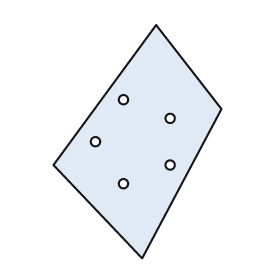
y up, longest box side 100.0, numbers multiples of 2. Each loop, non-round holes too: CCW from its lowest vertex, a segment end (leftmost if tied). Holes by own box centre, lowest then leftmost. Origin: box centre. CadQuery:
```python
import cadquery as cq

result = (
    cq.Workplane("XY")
    .moveTo(2.0, -50.0)
    .lineTo(36.0, 14.0)
    .lineTo(8.0, 50.0)
    .lineTo(-36.0, -10.0)
    .close()
    .moveTo(-6.0, -18.0)
    .circle(2.0)
    .moveTo(14.0, -10.0)
    .circle(2.0)
    .moveTo(-18.0, 0.0)
    .circle(2.0)
    .moveTo(14.0, 10.0)
    .circle(2.0)
    .moveTo(-6.0, 18.0)
    .circle(2.0)
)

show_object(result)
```